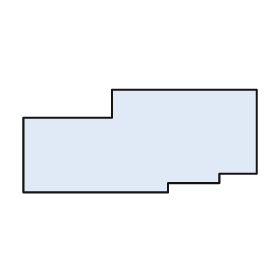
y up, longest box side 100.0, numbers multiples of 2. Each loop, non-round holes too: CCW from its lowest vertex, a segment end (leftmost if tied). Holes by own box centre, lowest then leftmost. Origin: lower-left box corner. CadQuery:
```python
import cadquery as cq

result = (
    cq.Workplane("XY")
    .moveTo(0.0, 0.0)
    .lineTo(62.0, 0.0)
    .lineTo(62.0, 4.0)
    .lineTo(84.0, 4.0)
    .lineTo(84.0, 8.0)
    .lineTo(100.0, 8.0)
    .lineTo(100.0, 44.0)
    .lineTo(38.0, 44.0)
    .lineTo(38.0, 32.0)
    .lineTo(0.0, 32.0)
    .close()
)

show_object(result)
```